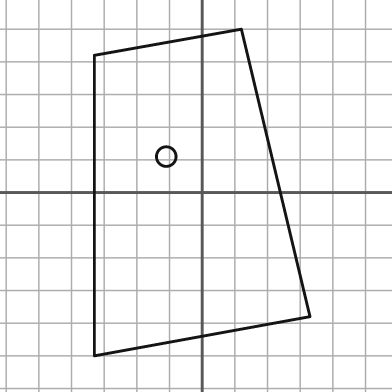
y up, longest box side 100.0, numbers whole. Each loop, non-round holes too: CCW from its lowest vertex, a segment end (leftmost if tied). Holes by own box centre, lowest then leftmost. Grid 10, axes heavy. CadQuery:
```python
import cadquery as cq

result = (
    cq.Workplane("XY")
    .moveTo(-33.0, -50.0)
    .lineTo(33.0, -38.0)
    .lineTo(12.0, 50.0)
    .lineTo(-33.0, 42.0)
    .close()
    .moveTo(-11.0, 11.0)
    .circle(3.0)
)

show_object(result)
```